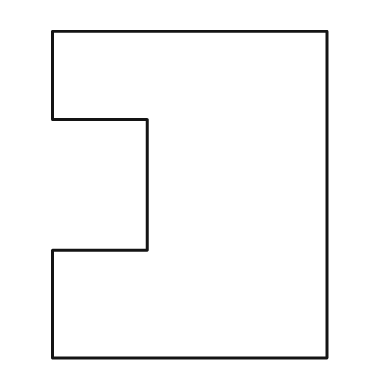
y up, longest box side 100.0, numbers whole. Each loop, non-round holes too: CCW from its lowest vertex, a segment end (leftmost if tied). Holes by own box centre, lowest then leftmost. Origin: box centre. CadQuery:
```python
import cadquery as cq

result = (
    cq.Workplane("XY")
    .moveTo(-42.0, -50.0)
    .lineTo(42.0, -50.0)
    .lineTo(42.0, 50.0)
    .lineTo(-42.0, 50.0)
    .lineTo(-42.0, 23.0)
    .lineTo(-13.0, 23.0)
    .lineTo(-13.0, -17.0)
    .lineTo(-42.0, -17.0)
    .close()
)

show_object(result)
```